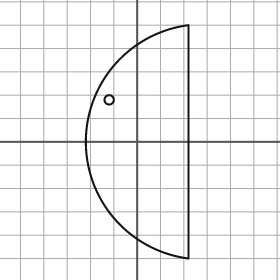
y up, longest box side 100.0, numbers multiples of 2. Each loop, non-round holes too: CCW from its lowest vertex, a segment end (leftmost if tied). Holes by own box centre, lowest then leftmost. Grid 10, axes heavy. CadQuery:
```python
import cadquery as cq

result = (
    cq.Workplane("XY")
    .moveTo(22.0, -50.0)
    .lineTo(22.0, 50.0)
    .threePointArc((-22.0, 0.0), (22.0, -50.0))
    .close()
    .moveTo(-12.0, 18.0)
    .circle(2.0)
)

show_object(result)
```